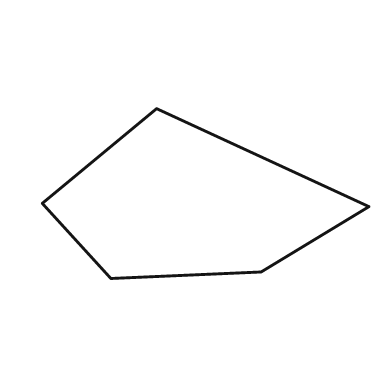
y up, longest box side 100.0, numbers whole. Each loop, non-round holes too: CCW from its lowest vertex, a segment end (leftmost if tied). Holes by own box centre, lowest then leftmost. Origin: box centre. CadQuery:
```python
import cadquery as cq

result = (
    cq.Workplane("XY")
    .moveTo(-29.0, -26.0)
    .lineTo(17.0, -24.0)
    .lineTo(50.0, -4.0)
    .lineTo(-15.0, 26.0)
    .lineTo(-50.0, -3.0)
    .close()
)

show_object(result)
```